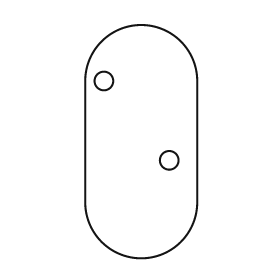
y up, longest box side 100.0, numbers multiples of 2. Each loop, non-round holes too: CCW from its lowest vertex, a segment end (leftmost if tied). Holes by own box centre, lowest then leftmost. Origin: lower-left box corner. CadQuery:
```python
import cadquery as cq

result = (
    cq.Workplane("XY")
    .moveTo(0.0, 24.0)
    .threePointArc((24.0, 0.0), (48.0, 24.0))
    .lineTo(48.0, 76.0)
    .threePointArc((24.0, 100.0), (0.0, 76.0))
    .close()
    .moveTo(36.0, 42.0)
    .circle(4.0)
    .moveTo(8.0, 76.0)
    .circle(4.0)
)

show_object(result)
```